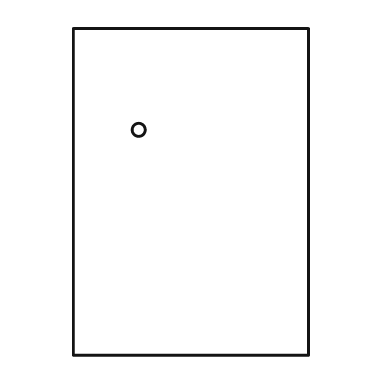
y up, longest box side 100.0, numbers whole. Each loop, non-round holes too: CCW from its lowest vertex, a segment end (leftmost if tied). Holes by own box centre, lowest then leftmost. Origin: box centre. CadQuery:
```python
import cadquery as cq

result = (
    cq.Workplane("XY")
    .moveTo(-36.0, -50.0)
    .lineTo(36.0, -50.0)
    .lineTo(36.0, 50.0)
    .lineTo(-36.0, 50.0)
    .close()
    .moveTo(-16.0, 19.0)
    .circle(2.0)
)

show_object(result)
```